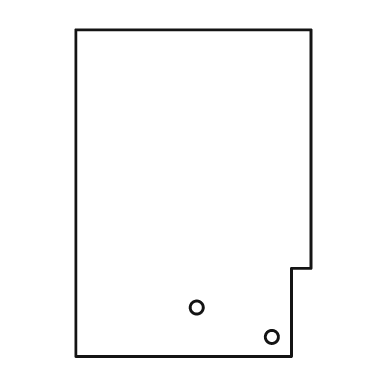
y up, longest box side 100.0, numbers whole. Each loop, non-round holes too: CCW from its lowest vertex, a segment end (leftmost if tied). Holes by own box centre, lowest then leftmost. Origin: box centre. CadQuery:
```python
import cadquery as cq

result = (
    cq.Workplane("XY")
    .moveTo(-36.0, -50.0)
    .lineTo(30.0, -50.0)
    .lineTo(30.0, -23.0)
    .lineTo(36.0, -23.0)
    .lineTo(36.0, 50.0)
    .lineTo(-36.0, 50.0)
    .close()
    .moveTo(24.0, -44.0)
    .circle(2.0)
    .moveTo(1.0, -35.0)
    .circle(2.0)
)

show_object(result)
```